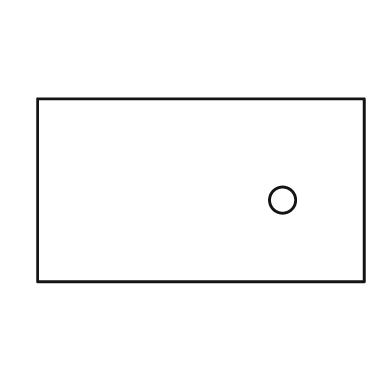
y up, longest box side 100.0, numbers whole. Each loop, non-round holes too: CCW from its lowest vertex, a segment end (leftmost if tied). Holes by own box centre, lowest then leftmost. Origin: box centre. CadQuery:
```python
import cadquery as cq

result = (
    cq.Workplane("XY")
    .moveTo(-50.0, -28.0)
    .lineTo(50.0, -28.0)
    .lineTo(50.0, 28.0)
    .lineTo(-50.0, 28.0)
    .close()
    .moveTo(25.0, -3.0)
    .circle(4.0)
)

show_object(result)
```